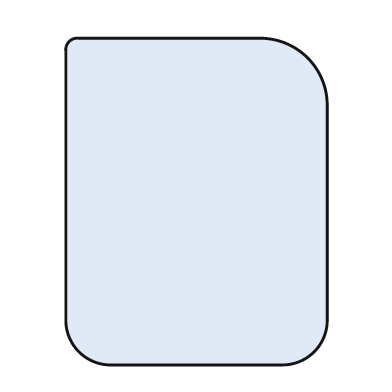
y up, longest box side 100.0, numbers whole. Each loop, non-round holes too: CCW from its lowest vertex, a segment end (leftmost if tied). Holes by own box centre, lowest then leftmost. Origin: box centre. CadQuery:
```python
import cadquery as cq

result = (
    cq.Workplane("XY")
    .moveTo(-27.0, -50.0)
    .lineTo(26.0, -50.0)
    .threePointArc((36.0, -46.0), (40.0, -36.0))
    .lineTo(40.0, 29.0)
    .threePointArc((34.0, 44.0), (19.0, 50.0))
    .lineTo(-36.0, 50.0)
    .threePointArc((-39.0, 49.0), (-40.0, 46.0))
    .lineTo(-40.0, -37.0)
    .threePointArc((-36.0, -46.0), (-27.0, -50.0))
    .close()
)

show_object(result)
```